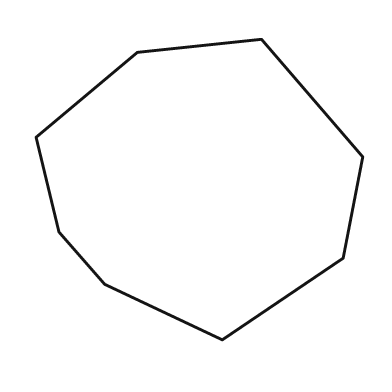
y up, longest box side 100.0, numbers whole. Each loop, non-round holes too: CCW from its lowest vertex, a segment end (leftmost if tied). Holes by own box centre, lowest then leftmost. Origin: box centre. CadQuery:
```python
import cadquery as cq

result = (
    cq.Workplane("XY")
    .moveTo(7.0, -46.0)
    .lineTo(44.0, -21.0)
    .lineTo(50.0, 10.0)
    .lineTo(19.0, 46.0)
    .lineTo(-19.0, 42.0)
    .lineTo(-50.0, 16.0)
    .lineTo(-43.0, -13.0)
    .lineTo(-29.0, -29.0)
    .close()
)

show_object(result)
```